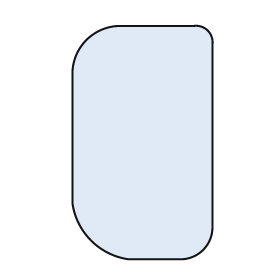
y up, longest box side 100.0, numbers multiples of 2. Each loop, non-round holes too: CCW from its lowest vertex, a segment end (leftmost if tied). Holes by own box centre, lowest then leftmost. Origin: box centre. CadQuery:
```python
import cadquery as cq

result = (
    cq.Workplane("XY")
    .moveTo(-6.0, -50.0)
    .lineTo(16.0, -50.0)
    .threePointArc((26.0, -46.0), (30.0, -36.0))
    .lineTo(30.0, 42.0)
    .threePointArc((28.0, 48.0), (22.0, 50.0))
    .lineTo(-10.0, 50.0)
    .threePointArc((-24.0, 44.0), (-30.0, 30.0))
    .lineTo(-30.0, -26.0)
    .threePointArc((-22.0, -42.0), (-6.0, -50.0))
    .close()
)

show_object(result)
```